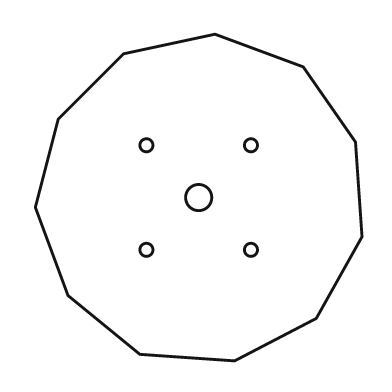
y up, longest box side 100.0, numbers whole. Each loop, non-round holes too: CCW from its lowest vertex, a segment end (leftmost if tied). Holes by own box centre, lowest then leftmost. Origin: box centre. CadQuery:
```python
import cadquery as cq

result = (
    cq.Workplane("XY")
    .moveTo(11.0, -50.0)
    .lineTo(36.0, -37.0)
    .lineTo(50.0, -12.0)
    .lineTo(48.0, 17.0)
    .lineTo(32.0, 40.0)
    .lineTo(5.0, 50.0)
    .lineTo(-23.0, 44.0)
    .lineTo(-43.0, 24.0)
    .lineTo(-50.0, -3.0)
    .lineTo(-40.0, -30.0)
    .lineTo(-18.0, -48.0)
    .close()
    .moveTo(-16.0, -16.0)
    .circle(2.0)
    .moveTo(16.0, -16.0)
    .circle(2.0)
    .moveTo(0.0, 0.0)
    .circle(4.0)
    .moveTo(-16.0, 16.0)
    .circle(2.0)
    .moveTo(16.0, 16.0)
    .circle(2.0)
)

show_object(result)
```